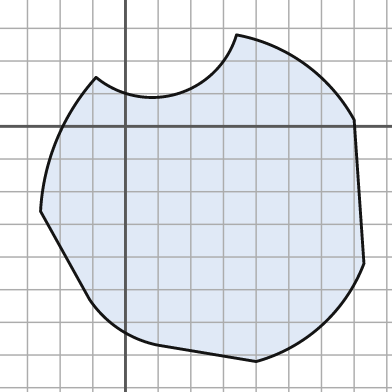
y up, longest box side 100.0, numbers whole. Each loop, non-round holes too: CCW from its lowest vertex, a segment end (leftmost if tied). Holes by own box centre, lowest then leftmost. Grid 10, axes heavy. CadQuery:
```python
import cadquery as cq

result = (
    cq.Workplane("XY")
    .moveTo(40.0, -72.0)
    .threePointArc((60.0, -61.0), (73.0, -42.0))
    .lineTo(70.0, 2.0)
    .threePointArc((55.0, 19.0), (34.0, 28.0))
    .threePointArc((16.0, 10.0), (-9.0, 15.0))
    .threePointArc((-21.0, -4.0), (-26.0, -26.0))
    .lineTo(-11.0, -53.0)
    .threePointArc((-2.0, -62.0), (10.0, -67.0))
    .close()
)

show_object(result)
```